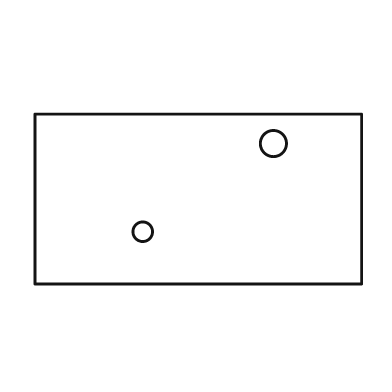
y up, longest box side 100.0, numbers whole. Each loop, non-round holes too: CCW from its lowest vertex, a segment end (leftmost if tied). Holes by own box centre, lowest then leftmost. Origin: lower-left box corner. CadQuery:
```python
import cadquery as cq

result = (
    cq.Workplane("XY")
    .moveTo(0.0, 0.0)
    .lineTo(100.0, 0.0)
    .lineTo(100.0, 52.0)
    .lineTo(0.0, 52.0)
    .close()
    .moveTo(33.0, 16.0)
    .circle(3.0)
    .moveTo(73.0, 43.0)
    .circle(4.0)
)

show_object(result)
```